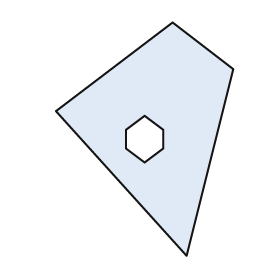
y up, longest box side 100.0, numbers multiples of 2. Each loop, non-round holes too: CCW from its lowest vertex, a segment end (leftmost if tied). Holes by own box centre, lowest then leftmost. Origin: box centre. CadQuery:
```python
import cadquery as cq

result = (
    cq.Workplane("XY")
    .moveTo(18.0, -50.0)
    .lineTo(38.0, 30.0)
    .lineTo(12.0, 50.0)
    .lineTo(-38.0, 12.0)
    .close()
    .moveTo(0.0, -10.0)
    .lineTo(8.0, -4.0)
    .lineTo(8.0, 4.0)
    .lineTo(0.0, 10.0)
    .lineTo(-8.0, 4.0)
    .lineTo(-8.0, -4.0)
    .close()
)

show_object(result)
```